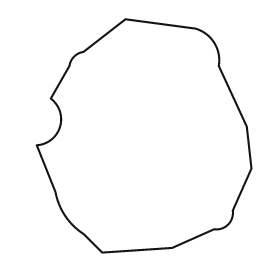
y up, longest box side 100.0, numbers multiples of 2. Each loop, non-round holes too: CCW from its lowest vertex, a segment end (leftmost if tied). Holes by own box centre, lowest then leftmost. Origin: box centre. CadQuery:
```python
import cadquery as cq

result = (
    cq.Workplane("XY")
    .moveTo(-18.0, -50.0)
    .lineTo(12.0, -48.0)
    .lineTo(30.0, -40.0)
    .threePointArc((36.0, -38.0), (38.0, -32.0))
    .lineTo(46.0, -14.0)
    .lineTo(44.0, 4.0)
    .lineTo(32.0, 30.0)
    .threePointArc((30.0, 40.0), (22.0, 46.0))
    .lineTo(-8.0, 50.0)
    .lineTo(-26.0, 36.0)
    .threePointArc((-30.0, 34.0), (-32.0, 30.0))
    .lineTo(-40.0, 16.0)
    .threePointArc((-36.0, 4.0), (-46.0, -4.0))
    .lineTo(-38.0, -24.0)
    .threePointArc((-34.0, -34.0), (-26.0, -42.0))
    .close()
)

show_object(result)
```